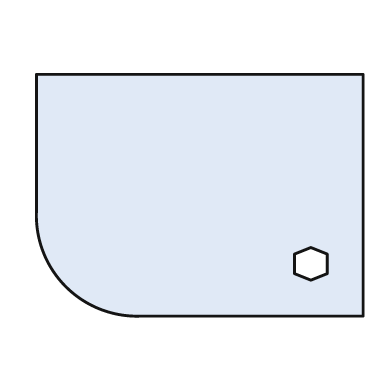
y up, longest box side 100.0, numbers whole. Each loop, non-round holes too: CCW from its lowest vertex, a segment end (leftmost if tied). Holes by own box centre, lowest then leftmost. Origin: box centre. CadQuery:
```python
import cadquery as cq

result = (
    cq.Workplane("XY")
    .moveTo(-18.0, -37.0)
    .lineTo(50.0, -37.0)
    .lineTo(50.0, 37.0)
    .lineTo(-50.0, 37.0)
    .lineTo(-50.0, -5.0)
    .threePointArc((-41.0, -28.0), (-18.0, -37.0))
    .close()
    .moveTo(34.0, -26.0)
    .lineTo(39.0, -24.0)
    .lineTo(39.0, -18.0)
    .lineTo(34.0, -16.0)
    .lineTo(29.0, -18.0)
    .lineTo(29.0, -24.0)
    .close()
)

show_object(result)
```